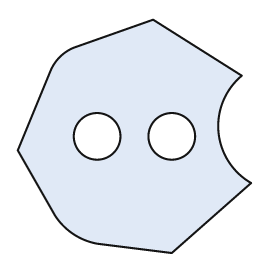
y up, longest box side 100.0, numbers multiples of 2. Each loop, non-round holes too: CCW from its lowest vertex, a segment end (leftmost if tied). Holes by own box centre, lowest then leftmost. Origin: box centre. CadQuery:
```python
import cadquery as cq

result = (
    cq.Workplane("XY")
    .moveTo(16.0, -50.0)
    .lineTo(50.0, -20.0)
    .threePointArc((36.0, 2.0), (46.0, 26.0))
    .lineTo(8.0, 50.0)
    .lineTo(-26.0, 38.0)
    .threePointArc((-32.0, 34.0), (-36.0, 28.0))
    .lineTo(-50.0, -6.0)
    .lineTo(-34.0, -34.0)
    .threePointArc((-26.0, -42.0), (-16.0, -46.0))
    .close()
    .moveTo(-16.0, 0.0)
    .circle(10.0)
    .moveTo(16.0, 0.0)
    .circle(10.0)
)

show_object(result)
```